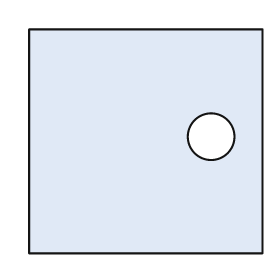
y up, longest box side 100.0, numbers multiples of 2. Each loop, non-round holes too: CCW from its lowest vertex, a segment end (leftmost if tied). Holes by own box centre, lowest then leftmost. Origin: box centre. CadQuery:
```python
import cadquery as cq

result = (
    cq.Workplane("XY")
    .moveTo(-50.0, -48.0)
    .lineTo(50.0, -48.0)
    .lineTo(50.0, 48.0)
    .lineTo(-50.0, 48.0)
    .close()
    .moveTo(28.0, 2.0)
    .circle(10.0)
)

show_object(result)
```